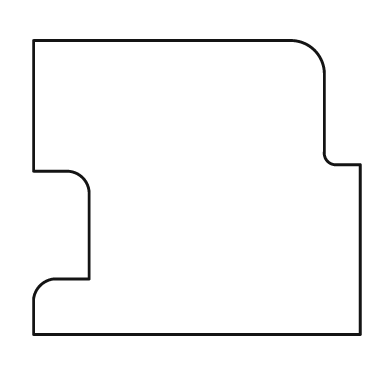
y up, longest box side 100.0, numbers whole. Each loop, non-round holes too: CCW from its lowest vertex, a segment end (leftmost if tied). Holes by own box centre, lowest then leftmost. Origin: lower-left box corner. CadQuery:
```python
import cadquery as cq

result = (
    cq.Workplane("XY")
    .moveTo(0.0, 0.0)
    .lineTo(100.0, 0.0)
    .lineTo(100.0, 52.0)
    .lineTo(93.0, 52.0)
    .threePointArc((90.0, 53.0), (89.0, 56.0))
    .lineTo(89.0, 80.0)
    .threePointArc((86.0, 87.0), (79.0, 90.0))
    .lineTo(0.0, 90.0)
    .lineTo(0.0, 50.0)
    .lineTo(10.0, 50.0)
    .threePointArc((15.0, 48.0), (17.0, 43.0))
    .lineTo(17.0, 17.0)
    .lineTo(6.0, 17.0)
    .threePointArc((2.0, 15.0), (0.0, 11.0))
    .close()
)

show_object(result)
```